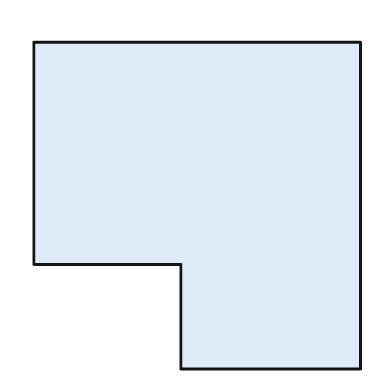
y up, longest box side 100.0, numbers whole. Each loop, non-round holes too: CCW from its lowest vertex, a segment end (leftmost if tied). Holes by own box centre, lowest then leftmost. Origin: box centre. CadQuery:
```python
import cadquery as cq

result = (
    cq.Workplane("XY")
    .moveTo(-5.0, -50.0)
    .lineTo(50.0, -50.0)
    .lineTo(50.0, 50.0)
    .lineTo(-50.0, 50.0)
    .lineTo(-50.0, -18.0)
    .lineTo(-5.0, -18.0)
    .close()
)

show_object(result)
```